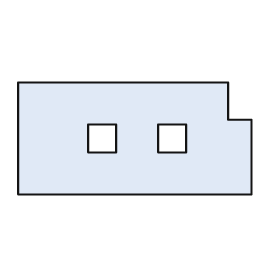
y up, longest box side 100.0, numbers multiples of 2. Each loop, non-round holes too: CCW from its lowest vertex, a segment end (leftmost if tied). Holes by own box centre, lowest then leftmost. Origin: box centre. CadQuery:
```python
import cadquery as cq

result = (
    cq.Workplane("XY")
    .moveTo(-50.0, -24.0)
    .lineTo(50.0, -24.0)
    .lineTo(50.0, 8.0)
    .lineTo(40.0, 8.0)
    .lineTo(40.0, 24.0)
    .lineTo(-50.0, 24.0)
    .close()
    .moveTo(-20.0, -6.0)
    .lineTo(-8.0, -6.0)
    .lineTo(-8.0, 6.0)
    .lineTo(-20.0, 6.0)
    .close()
    .moveTo(10.0, -6.0)
    .lineTo(22.0, -6.0)
    .lineTo(22.0, 6.0)
    .lineTo(10.0, 6.0)
    .close()
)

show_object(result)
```